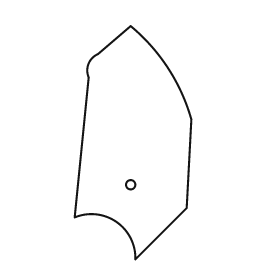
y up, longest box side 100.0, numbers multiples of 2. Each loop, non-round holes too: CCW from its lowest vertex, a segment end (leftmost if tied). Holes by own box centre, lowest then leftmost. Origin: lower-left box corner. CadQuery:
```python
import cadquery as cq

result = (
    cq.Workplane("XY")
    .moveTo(26.0, 0.0)
    .lineTo(48.0, 22.0)
    .lineTo(50.0, 60.0)
    .threePointArc((40.0, 82.0), (24.0, 100.0))
    .lineTo(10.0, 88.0)
    .threePointArc((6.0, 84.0), (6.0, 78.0))
    .lineTo(0.0, 18.0)
    .threePointArc((18.0, 16.0), (26.0, 0.0))
    .close()
    .moveTo(24.0, 32.0)
    .circle(2.0)
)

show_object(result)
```